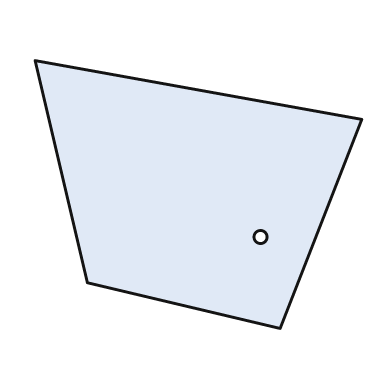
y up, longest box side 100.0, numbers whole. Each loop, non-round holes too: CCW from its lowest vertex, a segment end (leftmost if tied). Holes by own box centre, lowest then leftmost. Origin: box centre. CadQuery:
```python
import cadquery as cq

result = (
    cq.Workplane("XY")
    .moveTo(25.0, -41.0)
    .lineTo(50.0, 23.0)
    .lineTo(-50.0, 41.0)
    .lineTo(-34.0, -27.0)
    .close()
    .moveTo(19.0, -13.0)
    .circle(2.0)
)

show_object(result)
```